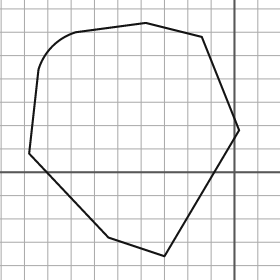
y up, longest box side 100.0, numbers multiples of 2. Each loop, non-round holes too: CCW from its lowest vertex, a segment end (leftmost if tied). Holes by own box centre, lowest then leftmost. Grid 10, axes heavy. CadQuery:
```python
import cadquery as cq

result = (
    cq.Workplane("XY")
    .moveTo(-30.0, -36.0)
    .lineTo(2.0, 18.0)
    .lineTo(-14.0, 58.0)
    .lineTo(-38.0, 64.0)
    .lineTo(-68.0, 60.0)
    .threePointArc((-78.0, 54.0), (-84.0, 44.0))
    .lineTo(-88.0, 8.0)
    .lineTo(-54.0, -28.0)
    .close()
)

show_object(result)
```